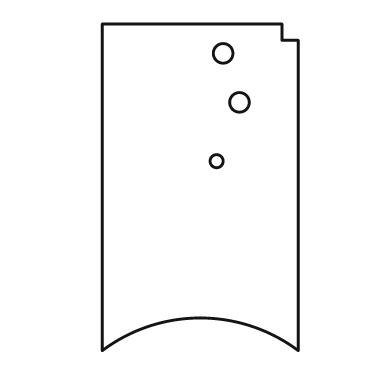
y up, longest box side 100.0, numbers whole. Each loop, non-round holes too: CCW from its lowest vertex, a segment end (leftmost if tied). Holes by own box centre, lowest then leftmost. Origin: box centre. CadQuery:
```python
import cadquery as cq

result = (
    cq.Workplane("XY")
    .moveTo(-30.0, -50.0)
    .threePointArc((0.0, -40.0), (30.0, -50.0))
    .lineTo(30.0, 45.0)
    .lineTo(25.0, 45.0)
    .lineTo(25.0, 50.0)
    .lineTo(-30.0, 50.0)
    .close()
    .moveTo(5.0, 8.0)
    .circle(2.0)
    .moveTo(12.0, 26.0)
    .circle(3.0)
    .moveTo(7.0, 41.0)
    .circle(3.0)
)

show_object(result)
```